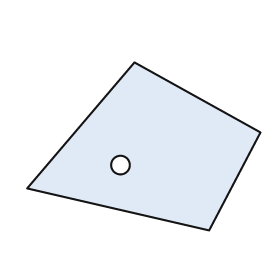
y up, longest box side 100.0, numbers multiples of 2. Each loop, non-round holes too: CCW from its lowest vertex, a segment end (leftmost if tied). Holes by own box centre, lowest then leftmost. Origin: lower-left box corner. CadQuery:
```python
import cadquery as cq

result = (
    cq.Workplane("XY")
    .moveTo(78.0, 0.0)
    .lineTo(100.0, 42.0)
    .lineTo(46.0, 72.0)
    .lineTo(0.0, 18.0)
    .close()
    .moveTo(40.0, 28.0)
    .circle(4.0)
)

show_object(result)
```